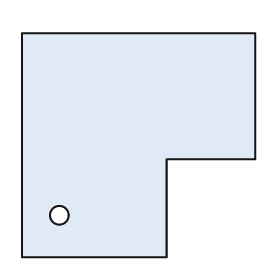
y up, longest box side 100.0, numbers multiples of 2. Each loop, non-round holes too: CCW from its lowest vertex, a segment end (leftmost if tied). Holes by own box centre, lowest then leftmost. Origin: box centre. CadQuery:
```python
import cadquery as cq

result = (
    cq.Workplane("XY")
    .moveTo(-50.0, -48.0)
    .lineTo(12.0, -48.0)
    .lineTo(12.0, -6.0)
    .lineTo(50.0, -6.0)
    .lineTo(50.0, 48.0)
    .lineTo(-50.0, 48.0)
    .close()
    .moveTo(-34.0, -30.0)
    .circle(4.0)
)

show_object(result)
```